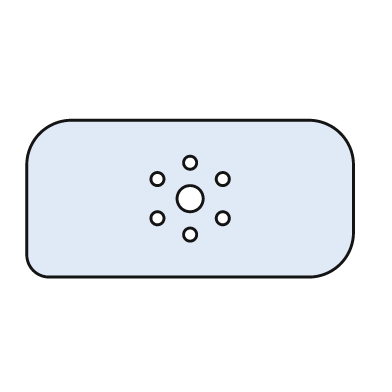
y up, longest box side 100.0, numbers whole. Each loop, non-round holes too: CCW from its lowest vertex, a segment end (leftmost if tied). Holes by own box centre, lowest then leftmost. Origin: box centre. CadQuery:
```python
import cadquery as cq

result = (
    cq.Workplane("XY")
    .moveTo(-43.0, -24.0)
    .lineTo(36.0, -24.0)
    .threePointArc((46.0, -20.0), (50.0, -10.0))
    .lineTo(50.0, 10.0)
    .threePointArc((46.0, 20.0), (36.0, 24.0))
    .lineTo(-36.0, 24.0)
    .threePointArc((-46.0, 20.0), (-50.0, 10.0))
    .lineTo(-50.0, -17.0)
    .threePointArc((-48.0, -22.0), (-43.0, -24.0))
    .close()
    .moveTo(0.0, -11.0)
    .circle(2.0)
    .moveTo(-10.0, -6.0)
    .circle(2.0)
    .moveTo(10.0, -6.0)
    .circle(2.0)
    .moveTo(0.0, 0.0)
    .circle(4.0)
    .moveTo(-10.0, 6.0)
    .circle(2.0)
    .moveTo(10.0, 6.0)
    .circle(2.0)
    .moveTo(0.0, 11.0)
    .circle(2.0)
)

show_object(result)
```